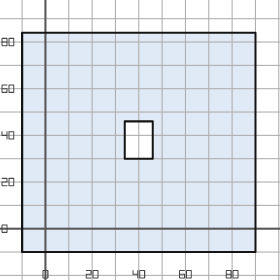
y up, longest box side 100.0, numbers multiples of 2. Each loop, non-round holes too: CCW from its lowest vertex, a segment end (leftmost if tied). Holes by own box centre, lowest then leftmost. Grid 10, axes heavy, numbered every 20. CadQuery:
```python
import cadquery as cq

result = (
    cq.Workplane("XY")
    .moveTo(-10.0, -10.0)
    .lineTo(90.0, -10.0)
    .lineTo(90.0, 84.0)
    .lineTo(-10.0, 84.0)
    .close()
    .moveTo(34.0, 30.0)
    .lineTo(46.0, 30.0)
    .lineTo(46.0, 46.0)
    .lineTo(34.0, 46.0)
    .close()
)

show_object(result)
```